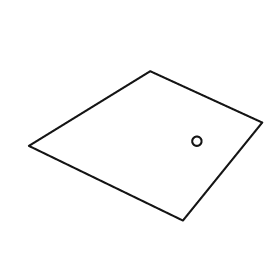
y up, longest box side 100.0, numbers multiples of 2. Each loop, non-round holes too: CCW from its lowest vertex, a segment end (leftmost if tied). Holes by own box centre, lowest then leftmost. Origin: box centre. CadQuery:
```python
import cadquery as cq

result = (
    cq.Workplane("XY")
    .moveTo(16.0, -32.0)
    .lineTo(50.0, 10.0)
    .lineTo(2.0, 32.0)
    .lineTo(-50.0, 0.0)
    .close()
    .moveTo(22.0, 2.0)
    .circle(2.0)
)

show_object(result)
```